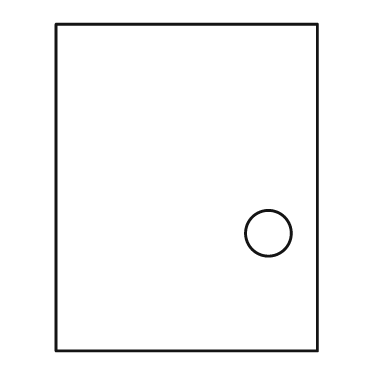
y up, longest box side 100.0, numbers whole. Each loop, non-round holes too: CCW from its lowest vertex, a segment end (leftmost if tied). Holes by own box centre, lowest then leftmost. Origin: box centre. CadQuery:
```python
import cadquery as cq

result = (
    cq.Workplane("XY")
    .moveTo(-40.0, -50.0)
    .lineTo(40.0, -50.0)
    .lineTo(40.0, 50.0)
    .lineTo(-40.0, 50.0)
    .close()
    .moveTo(25.0, -14.0)
    .circle(7.0)
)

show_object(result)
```